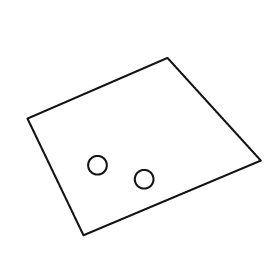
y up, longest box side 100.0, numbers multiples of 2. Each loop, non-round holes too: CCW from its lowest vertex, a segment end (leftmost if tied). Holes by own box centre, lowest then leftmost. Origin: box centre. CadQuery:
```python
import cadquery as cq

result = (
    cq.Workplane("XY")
    .moveTo(-26.0, -38.0)
    .lineTo(50.0, -6.0)
    .lineTo(10.0, 38.0)
    .lineTo(-50.0, 12.0)
    .close()
    .moveTo(0.0, -14.0)
    .circle(4.0)
    .moveTo(-20.0, -8.0)
    .circle(4.0)
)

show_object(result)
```